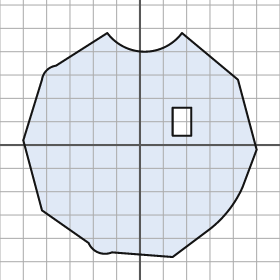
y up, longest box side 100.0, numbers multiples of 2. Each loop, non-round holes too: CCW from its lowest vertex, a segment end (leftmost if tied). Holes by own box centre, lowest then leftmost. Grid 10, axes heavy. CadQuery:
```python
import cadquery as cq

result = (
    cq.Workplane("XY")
    .moveTo(14.0, -48.0)
    .lineTo(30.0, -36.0)
    .threePointArc((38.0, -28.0), (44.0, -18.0))
    .lineTo(50.0, -2.0)
    .lineTo(42.0, 28.0)
    .lineTo(18.0, 48.0)
    .threePointArc((2.0, 40.0), (-14.0, 48.0))
    .lineTo(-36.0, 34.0)
    .threePointArc((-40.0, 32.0), (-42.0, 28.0))
    .lineTo(-50.0, 2.0)
    .lineTo(-42.0, -28.0)
    .lineTo(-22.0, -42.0)
    .threePointArc((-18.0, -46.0), (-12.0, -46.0))
    .close()
    .moveTo(14.0, 4.0)
    .lineTo(22.0, 4.0)
    .lineTo(22.0, 16.0)
    .lineTo(14.0, 16.0)
    .close()
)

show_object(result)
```